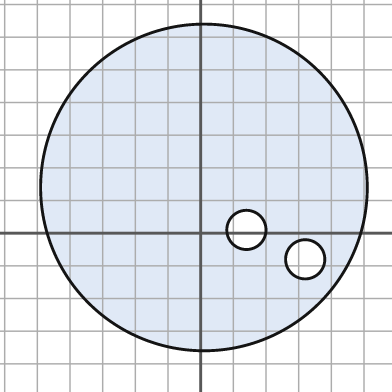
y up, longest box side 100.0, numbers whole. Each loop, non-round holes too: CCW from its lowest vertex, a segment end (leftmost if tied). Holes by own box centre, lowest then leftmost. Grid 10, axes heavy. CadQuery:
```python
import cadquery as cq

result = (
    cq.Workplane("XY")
    .moveTo(1.0, 14.0)
    .circle(50.0)
    .moveTo(32.0, -8.0)
    .circle(6.0)
    .moveTo(14.0, 1.0)
    .circle(6.0)
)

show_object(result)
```